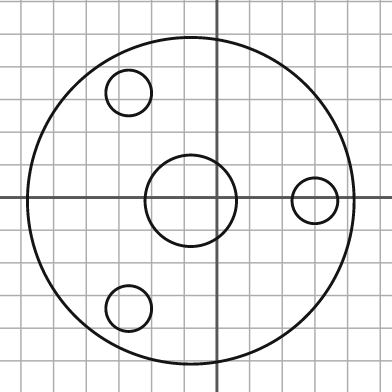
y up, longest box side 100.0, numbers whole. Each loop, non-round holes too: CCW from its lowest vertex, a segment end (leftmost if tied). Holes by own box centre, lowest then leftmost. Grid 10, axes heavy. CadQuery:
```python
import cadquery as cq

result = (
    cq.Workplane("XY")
    .moveTo(-8.0, -1.0)
    .circle(50.0)
    .moveTo(-27.0, -34.0)
    .circle(7.0)
    .moveTo(-8.0, -1.0)
    .circle(14.0)
    .moveTo(30.0, -1.0)
    .circle(7.0)
    .moveTo(-27.0, 32.0)
    .circle(7.0)
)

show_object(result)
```